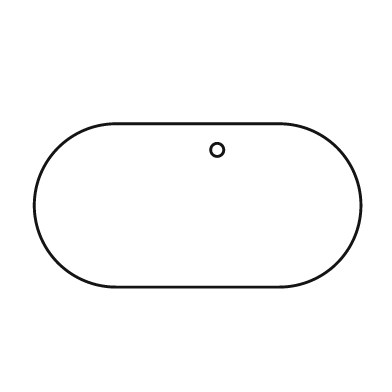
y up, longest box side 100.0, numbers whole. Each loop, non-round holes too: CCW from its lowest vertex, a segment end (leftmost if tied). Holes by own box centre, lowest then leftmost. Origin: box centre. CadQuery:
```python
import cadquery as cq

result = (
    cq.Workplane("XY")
    .moveTo(-25.0, -25.0)
    .lineTo(25.0, -25.0)
    .threePointArc((50.0, 0.0), (25.0, 25.0))
    .lineTo(-25.0, 25.0)
    .threePointArc((-50.0, 0.0), (-25.0, -25.0))
    .close()
    .moveTo(6.0, 17.0)
    .circle(2.0)
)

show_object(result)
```